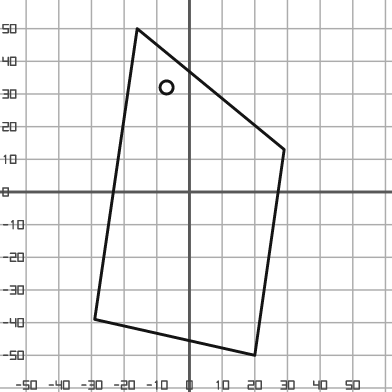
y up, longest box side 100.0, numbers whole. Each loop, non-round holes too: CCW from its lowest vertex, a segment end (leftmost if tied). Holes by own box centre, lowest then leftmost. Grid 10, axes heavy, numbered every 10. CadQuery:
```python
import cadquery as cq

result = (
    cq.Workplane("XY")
    .moveTo(20.0, -50.0)
    .lineTo(29.0, 13.0)
    .lineTo(-16.0, 50.0)
    .lineTo(-29.0, -39.0)
    .close()
    .moveTo(-7.0, 32.0)
    .circle(2.0)
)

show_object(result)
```